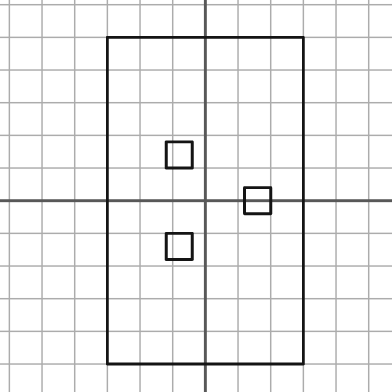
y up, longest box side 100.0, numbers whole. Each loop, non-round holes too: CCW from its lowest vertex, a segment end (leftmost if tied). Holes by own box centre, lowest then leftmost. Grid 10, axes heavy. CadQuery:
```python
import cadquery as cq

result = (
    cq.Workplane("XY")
    .moveTo(-30.0, -50.0)
    .lineTo(30.0, -50.0)
    .lineTo(30.0, 50.0)
    .lineTo(-30.0, 50.0)
    .close()
    .moveTo(-12.0, -18.0)
    .lineTo(-4.0, -18.0)
    .lineTo(-4.0, -10.0)
    .lineTo(-12.0, -10.0)
    .close()
    .moveTo(12.0, -4.0)
    .lineTo(20.0, -4.0)
    .lineTo(20.0, 4.0)
    .lineTo(12.0, 4.0)
    .close()
    .moveTo(-12.0, 10.0)
    .lineTo(-4.0, 10.0)
    .lineTo(-4.0, 18.0)
    .lineTo(-12.0, 18.0)
    .close()
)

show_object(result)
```